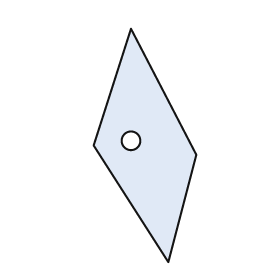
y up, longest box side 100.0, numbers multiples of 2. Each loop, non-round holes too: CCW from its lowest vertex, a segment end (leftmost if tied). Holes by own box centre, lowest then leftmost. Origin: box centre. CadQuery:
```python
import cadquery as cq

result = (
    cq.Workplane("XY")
    .moveTo(10.0, -50.0)
    .lineTo(22.0, -4.0)
    .lineTo(-6.0, 50.0)
    .lineTo(-22.0, 0.0)
    .close()
    .moveTo(-6.0, 2.0)
    .circle(4.0)
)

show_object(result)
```